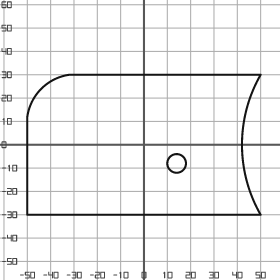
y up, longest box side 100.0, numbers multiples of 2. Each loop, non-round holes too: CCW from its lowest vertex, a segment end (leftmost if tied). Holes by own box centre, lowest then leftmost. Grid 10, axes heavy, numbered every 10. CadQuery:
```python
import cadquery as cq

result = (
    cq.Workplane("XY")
    .moveTo(-50.0, -30.0)
    .lineTo(50.0, -30.0)
    .threePointArc((42.0, 0.0), (50.0, 30.0))
    .lineTo(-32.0, 30.0)
    .threePointArc((-44.0, 24.0), (-50.0, 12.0))
    .close()
    .moveTo(14.0, -8.0)
    .circle(4.0)
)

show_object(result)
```